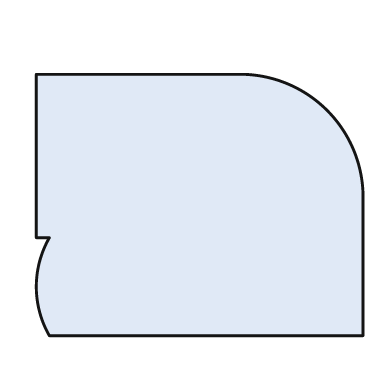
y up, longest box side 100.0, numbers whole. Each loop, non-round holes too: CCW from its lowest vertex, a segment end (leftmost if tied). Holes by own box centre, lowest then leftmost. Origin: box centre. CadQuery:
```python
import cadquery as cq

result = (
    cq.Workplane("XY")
    .moveTo(-46.0, -40.0)
    .lineTo(50.0, -40.0)
    .lineTo(50.0, 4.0)
    .threePointArc((39.0, 29.0), (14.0, 40.0))
    .lineTo(-50.0, 40.0)
    .lineTo(-50.0, -10.0)
    .lineTo(-46.0, -10.0)
    .threePointArc((-50.0, -25.0), (-46.0, -40.0))
    .close()
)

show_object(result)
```